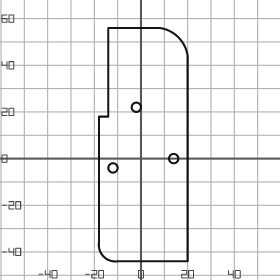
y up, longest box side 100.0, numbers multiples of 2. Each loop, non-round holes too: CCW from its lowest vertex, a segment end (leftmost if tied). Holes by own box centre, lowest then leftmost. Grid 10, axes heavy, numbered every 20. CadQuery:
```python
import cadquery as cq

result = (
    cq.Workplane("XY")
    .moveTo(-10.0, -44.0)
    .lineTo(20.0, -44.0)
    .lineTo(20.0, 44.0)
    .threePointArc((16.0, 52.0), (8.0, 56.0))
    .lineTo(-14.0, 56.0)
    .lineTo(-14.0, 18.0)
    .lineTo(-18.0, 18.0)
    .lineTo(-18.0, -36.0)
    .threePointArc((-16.0, -42.0), (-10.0, -44.0))
    .close()
    .moveTo(-12.0, -4.0)
    .circle(2.0)
    .moveTo(14.0, 0.0)
    .circle(2.0)
    .moveTo(-2.0, 22.0)
    .circle(2.0)
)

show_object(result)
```